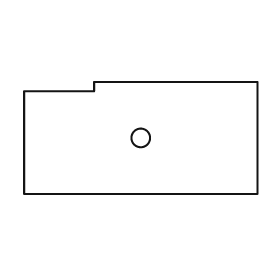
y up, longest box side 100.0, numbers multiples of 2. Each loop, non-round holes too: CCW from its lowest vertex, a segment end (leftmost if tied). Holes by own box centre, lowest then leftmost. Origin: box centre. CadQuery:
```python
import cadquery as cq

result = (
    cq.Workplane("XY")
    .moveTo(-50.0, -24.0)
    .lineTo(50.0, -24.0)
    .lineTo(50.0, 24.0)
    .lineTo(-20.0, 24.0)
    .lineTo(-20.0, 20.0)
    .lineTo(-50.0, 20.0)
    .close()
    .moveTo(0.0, 0.0)
    .circle(4.0)
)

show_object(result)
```